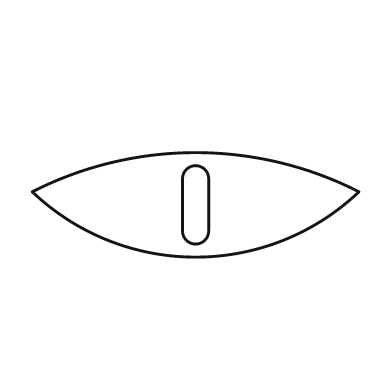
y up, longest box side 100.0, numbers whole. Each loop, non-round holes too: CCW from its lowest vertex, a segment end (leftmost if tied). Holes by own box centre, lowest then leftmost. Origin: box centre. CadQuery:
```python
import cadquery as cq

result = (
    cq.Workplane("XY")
    .moveTo(-50.0, 4.0)
    .threePointArc((0.0, -16.0), (50.0, 4.0))
    .threePointArc((0.0, 16.0), (-50.0, 4.0))
    .close()
    .moveTo(-4.0, -8.0)
    .threePointArc((0.0, -12.0), (4.0, -8.0))
    .lineTo(4.0, 8.0)
    .threePointArc((0.0, 12.0), (-4.0, 8.0))
    .close()
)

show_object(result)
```